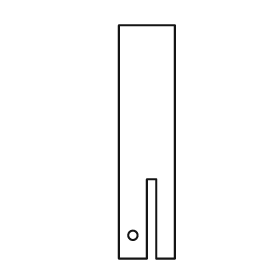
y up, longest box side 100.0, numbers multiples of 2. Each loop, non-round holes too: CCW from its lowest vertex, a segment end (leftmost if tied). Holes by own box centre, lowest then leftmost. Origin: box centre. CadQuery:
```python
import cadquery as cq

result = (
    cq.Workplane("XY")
    .moveTo(-12.0, -50.0)
    .lineTo(0.0, -50.0)
    .lineTo(0.0, -16.0)
    .lineTo(4.0, -16.0)
    .lineTo(4.0, -50.0)
    .lineTo(12.0, -50.0)
    .lineTo(12.0, 50.0)
    .lineTo(-12.0, 50.0)
    .close()
    .moveTo(-6.0, -40.0)
    .circle(2.0)
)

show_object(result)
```